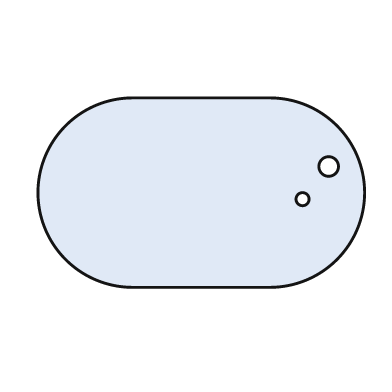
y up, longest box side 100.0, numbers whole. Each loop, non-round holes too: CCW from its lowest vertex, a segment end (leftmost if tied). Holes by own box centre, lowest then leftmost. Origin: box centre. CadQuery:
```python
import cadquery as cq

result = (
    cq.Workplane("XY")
    .moveTo(-21.0, -29.0)
    .lineTo(21.0, -29.0)
    .threePointArc((50.0, 0.0), (21.0, 29.0))
    .lineTo(-21.0, 29.0)
    .threePointArc((-50.0, 0.0), (-21.0, -29.0))
    .close()
    .moveTo(31.0, -2.0)
    .circle(2.0)
    .moveTo(39.0, 8.0)
    .circle(3.0)
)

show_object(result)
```